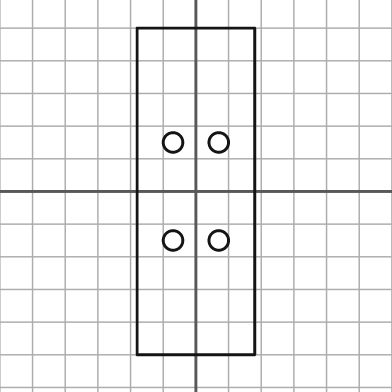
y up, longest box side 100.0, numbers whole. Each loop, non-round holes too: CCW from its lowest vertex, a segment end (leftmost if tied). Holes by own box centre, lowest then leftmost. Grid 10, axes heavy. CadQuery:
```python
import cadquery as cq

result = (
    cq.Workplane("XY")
    .moveTo(-18.0, -50.0)
    .lineTo(18.0, -50.0)
    .lineTo(18.0, 50.0)
    .lineTo(-18.0, 50.0)
    .close()
    .moveTo(-7.0, -15.0)
    .circle(3.0)
    .moveTo(7.0, -15.0)
    .circle(3.0)
    .moveTo(-7.0, 15.0)
    .circle(3.0)
    .moveTo(7.0, 15.0)
    .circle(3.0)
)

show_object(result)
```